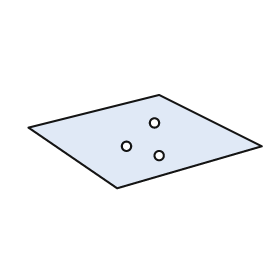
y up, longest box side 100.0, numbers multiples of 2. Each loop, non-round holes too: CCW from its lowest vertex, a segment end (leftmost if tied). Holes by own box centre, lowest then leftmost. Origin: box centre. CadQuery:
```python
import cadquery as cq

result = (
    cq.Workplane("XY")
    .moveTo(-12.0, -20.0)
    .lineTo(50.0, -2.0)
    .lineTo(6.0, 20.0)
    .lineTo(-50.0, 6.0)
    .close()
    .moveTo(6.0, -6.0)
    .circle(2.0)
    .moveTo(-8.0, -2.0)
    .circle(2.0)
    .moveTo(4.0, 8.0)
    .circle(2.0)
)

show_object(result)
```